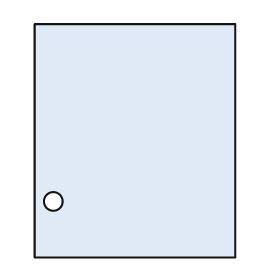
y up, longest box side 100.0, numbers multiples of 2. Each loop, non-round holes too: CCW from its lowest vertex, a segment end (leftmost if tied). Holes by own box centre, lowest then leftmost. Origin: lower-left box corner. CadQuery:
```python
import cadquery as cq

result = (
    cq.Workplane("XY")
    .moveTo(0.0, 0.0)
    .lineTo(86.0, 0.0)
    .lineTo(86.0, 100.0)
    .lineTo(0.0, 100.0)
    .close()
    .moveTo(8.0, 24.0)
    .circle(4.0)
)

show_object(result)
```